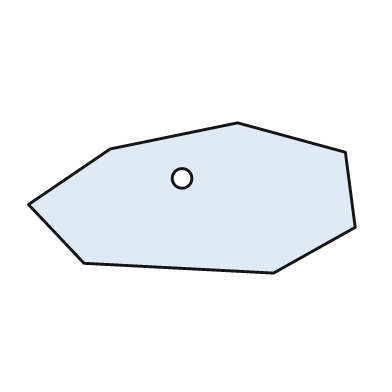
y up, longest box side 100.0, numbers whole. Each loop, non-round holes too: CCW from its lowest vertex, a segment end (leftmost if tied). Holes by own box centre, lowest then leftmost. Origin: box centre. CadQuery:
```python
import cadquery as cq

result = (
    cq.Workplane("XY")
    .moveTo(25.0, -23.0)
    .lineTo(50.0, -9.0)
    .lineTo(47.0, 14.0)
    .lineTo(14.0, 23.0)
    .lineTo(-25.0, 15.0)
    .lineTo(-50.0, -2.0)
    .lineTo(-33.0, -20.0)
    .close()
    .moveTo(-3.0, 6.0)
    .circle(3.0)
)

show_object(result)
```